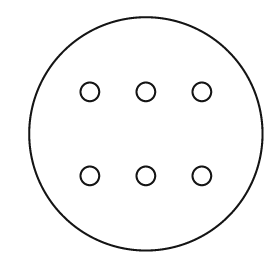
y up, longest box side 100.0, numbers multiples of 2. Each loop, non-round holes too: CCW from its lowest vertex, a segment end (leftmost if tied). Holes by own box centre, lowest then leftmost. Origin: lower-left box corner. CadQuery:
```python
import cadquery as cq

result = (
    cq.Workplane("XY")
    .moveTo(50.0, 50.0)
    .circle(50.0)
    .moveTo(26.0, 32.0)
    .circle(4.0)
    .moveTo(50.0, 32.0)
    .circle(4.0)
    .moveTo(74.0, 32.0)
    .circle(4.0)
    .moveTo(26.0, 68.0)
    .circle(4.0)
    .moveTo(50.0, 68.0)
    .circle(4.0)
    .moveTo(74.0, 68.0)
    .circle(4.0)
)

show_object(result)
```